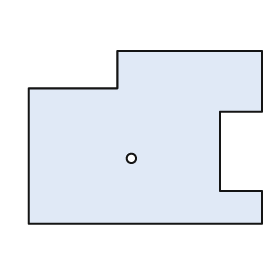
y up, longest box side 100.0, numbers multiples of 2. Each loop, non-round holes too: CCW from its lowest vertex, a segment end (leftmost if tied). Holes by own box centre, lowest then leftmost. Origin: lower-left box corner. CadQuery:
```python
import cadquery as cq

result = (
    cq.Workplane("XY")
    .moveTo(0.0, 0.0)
    .lineTo(100.0, 0.0)
    .lineTo(100.0, 14.0)
    .lineTo(82.0, 14.0)
    .lineTo(82.0, 48.0)
    .lineTo(100.0, 48.0)
    .lineTo(100.0, 74.0)
    .lineTo(38.0, 74.0)
    .lineTo(38.0, 58.0)
    .lineTo(0.0, 58.0)
    .close()
    .moveTo(44.0, 28.0)
    .circle(2.0)
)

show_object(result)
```